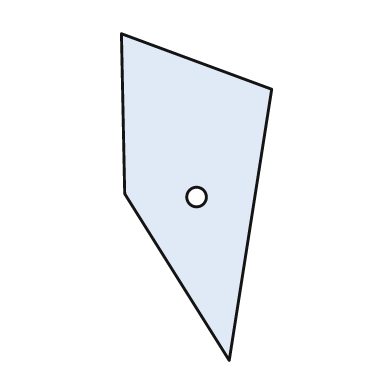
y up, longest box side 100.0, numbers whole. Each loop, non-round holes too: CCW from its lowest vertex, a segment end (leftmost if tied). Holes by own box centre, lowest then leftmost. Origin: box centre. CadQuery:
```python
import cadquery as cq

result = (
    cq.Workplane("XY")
    .moveTo(10.0, -50.0)
    .lineTo(23.0, 33.0)
    .lineTo(-23.0, 50.0)
    .lineTo(-22.0, 1.0)
    .close()
    .moveTo(0.0, 0.0)
    .circle(3.0)
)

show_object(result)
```